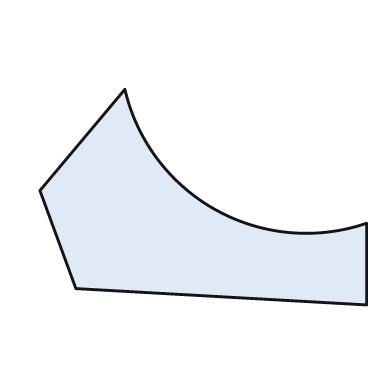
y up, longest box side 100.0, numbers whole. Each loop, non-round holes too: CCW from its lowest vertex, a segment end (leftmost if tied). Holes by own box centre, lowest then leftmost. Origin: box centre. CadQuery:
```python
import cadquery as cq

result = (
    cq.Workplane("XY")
    .moveTo(50.0, -33.0)
    .lineTo(50.0, -8.0)
    .threePointArc((4.0, -4.0), (-24.0, 33.0))
    .lineTo(-50.0, 2.0)
    .lineTo(-39.0, -28.0)
    .close()
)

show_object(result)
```